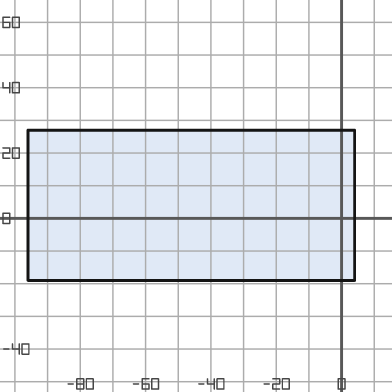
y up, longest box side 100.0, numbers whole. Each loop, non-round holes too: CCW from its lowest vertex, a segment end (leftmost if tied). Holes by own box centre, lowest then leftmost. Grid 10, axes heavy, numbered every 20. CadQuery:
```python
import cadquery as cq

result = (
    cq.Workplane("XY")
    .moveTo(-96.0, -19.0)
    .lineTo(4.0, -19.0)
    .lineTo(4.0, 27.0)
    .lineTo(-96.0, 27.0)
    .close()
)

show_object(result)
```